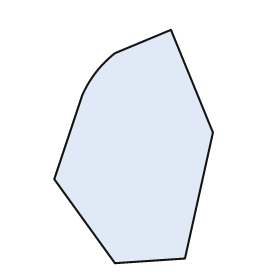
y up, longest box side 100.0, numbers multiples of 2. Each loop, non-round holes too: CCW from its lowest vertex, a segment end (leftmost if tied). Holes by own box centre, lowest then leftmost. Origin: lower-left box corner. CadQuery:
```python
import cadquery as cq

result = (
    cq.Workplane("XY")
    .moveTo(26.0, 0.0)
    .lineTo(56.0, 2.0)
    .lineTo(68.0, 56.0)
    .lineTo(50.0, 100.0)
    .lineTo(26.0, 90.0)
    .threePointArc((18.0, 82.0), (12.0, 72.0))
    .lineTo(0.0, 36.0)
    .close()
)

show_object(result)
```